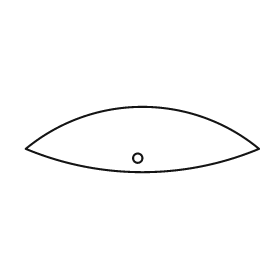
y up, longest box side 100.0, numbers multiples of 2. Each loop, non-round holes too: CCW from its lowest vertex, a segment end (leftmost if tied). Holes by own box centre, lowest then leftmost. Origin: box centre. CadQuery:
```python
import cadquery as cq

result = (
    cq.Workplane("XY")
    .moveTo(-50.0, -4.0)
    .threePointArc((0.0, -14.0), (50.0, -4.0))
    .threePointArc((0.0, 14.0), (-50.0, -4.0))
    .close()
    .moveTo(-2.0, -8.0)
    .circle(2.0)
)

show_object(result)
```